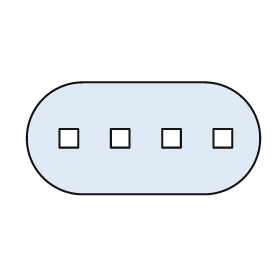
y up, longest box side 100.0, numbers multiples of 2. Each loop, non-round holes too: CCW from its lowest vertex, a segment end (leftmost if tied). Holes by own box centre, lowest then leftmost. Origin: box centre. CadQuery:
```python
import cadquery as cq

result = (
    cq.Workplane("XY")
    .moveTo(-26.0, -24.0)
    .lineTo(26.0, -24.0)
    .threePointArc((50.0, 0.0), (26.0, 24.0))
    .lineTo(-26.0, 24.0)
    .threePointArc((-50.0, 0.0), (-26.0, -24.0))
    .close()
    .moveTo(-36.0, -4.0)
    .lineTo(-28.0, -4.0)
    .lineTo(-28.0, 4.0)
    .lineTo(-36.0, 4.0)
    .close()
    .moveTo(-14.0, -4.0)
    .lineTo(-6.0, -4.0)
    .lineTo(-6.0, 4.0)
    .lineTo(-14.0, 4.0)
    .close()
    .moveTo(8.0, -4.0)
    .lineTo(16.0, -4.0)
    .lineTo(16.0, 4.0)
    .lineTo(8.0, 4.0)
    .close()
    .moveTo(30.0, -4.0)
    .lineTo(38.0, -4.0)
    .lineTo(38.0, 4.0)
    .lineTo(30.0, 4.0)
    .close()
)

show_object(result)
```